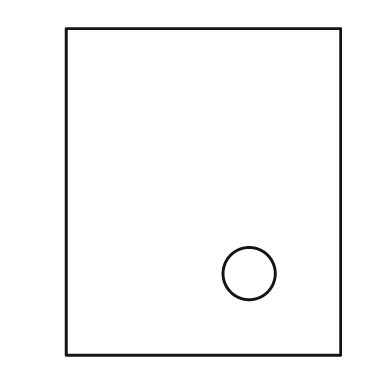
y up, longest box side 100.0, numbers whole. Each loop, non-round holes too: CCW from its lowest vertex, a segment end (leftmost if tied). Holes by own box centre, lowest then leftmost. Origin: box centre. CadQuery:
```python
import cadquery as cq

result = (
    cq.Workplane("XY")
    .moveTo(-42.0, -50.0)
    .lineTo(42.0, -50.0)
    .lineTo(42.0, 50.0)
    .lineTo(-42.0, 50.0)
    .close()
    .moveTo(14.0, -25.0)
    .circle(8.0)
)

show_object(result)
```